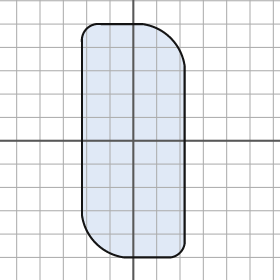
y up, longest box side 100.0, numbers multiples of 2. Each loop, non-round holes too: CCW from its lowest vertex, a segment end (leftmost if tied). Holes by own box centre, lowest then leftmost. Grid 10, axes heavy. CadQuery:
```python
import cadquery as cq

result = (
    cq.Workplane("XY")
    .moveTo(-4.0, -50.0)
    .lineTo(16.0, -50.0)
    .threePointArc((20.0, -48.0), (22.0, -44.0))
    .lineTo(22.0, 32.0)
    .threePointArc((16.0, 44.0), (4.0, 50.0))
    .lineTo(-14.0, 50.0)
    .threePointArc((-20.0, 48.0), (-22.0, 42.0))
    .lineTo(-22.0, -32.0)
    .threePointArc((-16.0, -44.0), (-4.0, -50.0))
    .close()
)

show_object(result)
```